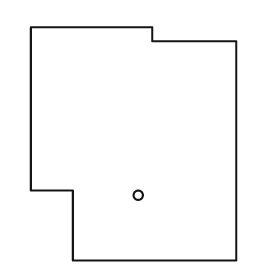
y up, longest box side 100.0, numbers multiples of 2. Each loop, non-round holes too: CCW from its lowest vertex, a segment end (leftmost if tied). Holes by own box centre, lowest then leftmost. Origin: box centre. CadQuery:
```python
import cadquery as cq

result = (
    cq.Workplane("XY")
    .moveTo(-26.0, -50.0)
    .lineTo(44.0, -50.0)
    .lineTo(44.0, 44.0)
    .lineTo(8.0, 44.0)
    .lineTo(8.0, 50.0)
    .lineTo(-44.0, 50.0)
    .lineTo(-44.0, -20.0)
    .lineTo(-26.0, -20.0)
    .close()
    .moveTo(2.0, -22.0)
    .circle(2.0)
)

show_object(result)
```